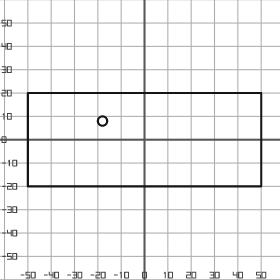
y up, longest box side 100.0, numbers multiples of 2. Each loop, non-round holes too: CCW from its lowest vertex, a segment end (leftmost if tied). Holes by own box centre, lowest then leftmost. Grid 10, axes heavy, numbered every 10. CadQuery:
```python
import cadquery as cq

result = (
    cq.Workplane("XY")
    .moveTo(-50.0, -20.0)
    .lineTo(50.0, -20.0)
    .lineTo(50.0, 20.0)
    .lineTo(-50.0, 20.0)
    .close()
    .moveTo(-18.0, 8.0)
    .circle(2.0)
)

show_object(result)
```